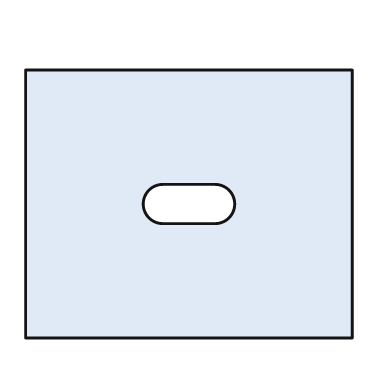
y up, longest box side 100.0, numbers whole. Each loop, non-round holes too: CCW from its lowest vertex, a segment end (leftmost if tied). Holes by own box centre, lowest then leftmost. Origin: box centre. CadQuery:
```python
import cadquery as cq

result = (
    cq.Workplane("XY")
    .moveTo(-50.0, -41.0)
    .lineTo(50.0, -41.0)
    .lineTo(50.0, 41.0)
    .lineTo(-50.0, 41.0)
    .close()
    .moveTo(-8.0, -6.0)
    .lineTo(8.0, -6.0)
    .threePointArc((14.0, 0.0), (8.0, 6.0))
    .lineTo(-8.0, 6.0)
    .threePointArc((-14.0, 0.0), (-8.0, -6.0))
    .close()
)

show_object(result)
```